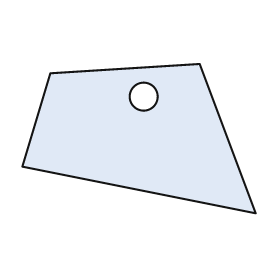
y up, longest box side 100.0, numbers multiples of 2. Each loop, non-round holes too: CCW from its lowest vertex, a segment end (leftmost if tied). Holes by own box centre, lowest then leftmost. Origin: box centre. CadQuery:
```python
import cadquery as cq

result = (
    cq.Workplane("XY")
    .moveTo(50.0, -32.0)
    .lineTo(26.0, 32.0)
    .lineTo(-38.0, 28.0)
    .lineTo(-50.0, -12.0)
    .close()
    .moveTo(2.0, 18.0)
    .circle(6.0)
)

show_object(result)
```